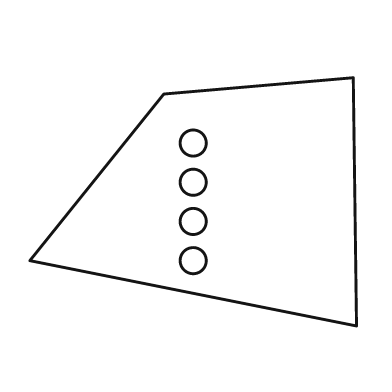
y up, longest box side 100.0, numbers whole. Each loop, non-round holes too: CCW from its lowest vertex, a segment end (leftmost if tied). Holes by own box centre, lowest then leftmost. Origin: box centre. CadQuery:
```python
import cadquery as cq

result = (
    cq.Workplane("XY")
    .moveTo(50.0, -38.0)
    .lineTo(49.0, 38.0)
    .lineTo(-9.0, 33.0)
    .lineTo(-50.0, -18.0)
    .close()
    .moveTo(0.0, -18.0)
    .circle(4.0)
    .moveTo(0.0, -6.0)
    .circle(4.0)
    .moveTo(0.0, 6.0)
    .circle(4.0)
    .moveTo(0.0, 18.0)
    .circle(4.0)
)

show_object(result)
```